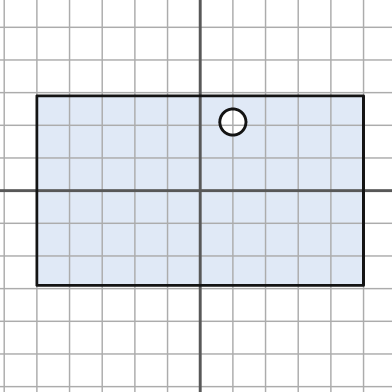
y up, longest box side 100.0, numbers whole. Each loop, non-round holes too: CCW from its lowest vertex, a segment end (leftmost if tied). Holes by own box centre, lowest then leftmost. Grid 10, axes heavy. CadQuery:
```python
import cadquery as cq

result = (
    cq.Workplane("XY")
    .moveTo(-50.0, -29.0)
    .lineTo(50.0, -29.0)
    .lineTo(50.0, 29.0)
    .lineTo(-50.0, 29.0)
    .close()
    .moveTo(10.0, 21.0)
    .circle(4.0)
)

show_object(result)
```